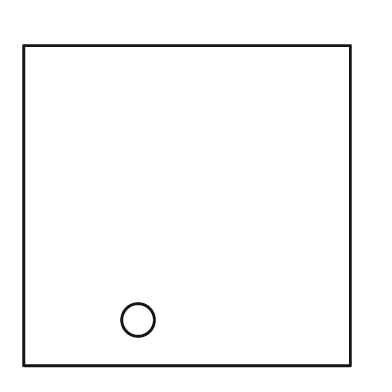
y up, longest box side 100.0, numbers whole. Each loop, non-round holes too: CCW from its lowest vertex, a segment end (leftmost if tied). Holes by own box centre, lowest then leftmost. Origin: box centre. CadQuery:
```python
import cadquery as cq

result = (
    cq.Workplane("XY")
    .moveTo(-50.0, -49.0)
    .lineTo(50.0, -49.0)
    .lineTo(50.0, 49.0)
    .lineTo(-50.0, 49.0)
    .close()
    .moveTo(-15.0, -35.0)
    .circle(5.0)
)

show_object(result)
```